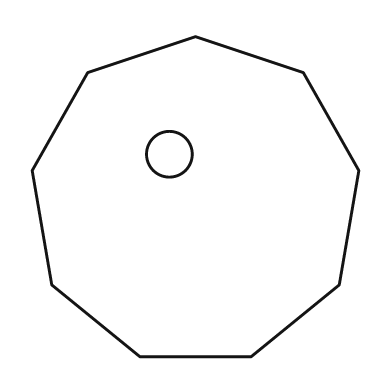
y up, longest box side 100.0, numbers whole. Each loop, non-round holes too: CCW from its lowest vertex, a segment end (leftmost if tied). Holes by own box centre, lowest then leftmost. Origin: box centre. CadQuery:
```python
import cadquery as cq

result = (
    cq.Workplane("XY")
    .moveTo(-17.0, -49.0)
    .lineTo(17.0, -49.0)
    .lineTo(44.0, -27.0)
    .lineTo(50.0, 8.0)
    .lineTo(33.0, 38.0)
    .lineTo(0.0, 49.0)
    .lineTo(-33.0, 38.0)
    .lineTo(-50.0, 8.0)
    .lineTo(-44.0, -27.0)
    .close()
    .moveTo(-8.0, 13.0)
    .circle(7.0)
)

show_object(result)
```